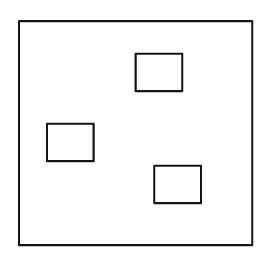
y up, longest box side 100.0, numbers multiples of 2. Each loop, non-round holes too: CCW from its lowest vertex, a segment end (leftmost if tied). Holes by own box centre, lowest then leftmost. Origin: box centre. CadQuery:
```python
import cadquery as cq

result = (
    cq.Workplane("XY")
    .moveTo(-50.0, -48.0)
    .lineTo(50.0, -48.0)
    .lineTo(50.0, 48.0)
    .lineTo(-50.0, 48.0)
    .close()
    .moveTo(8.0, -30.0)
    .lineTo(28.0, -30.0)
    .lineTo(28.0, -14.0)
    .lineTo(8.0, -14.0)
    .close()
    .moveTo(-38.0, -12.0)
    .lineTo(-18.0, -12.0)
    .lineTo(-18.0, 4.0)
    .lineTo(-38.0, 4.0)
    .close()
    .moveTo(0.0, 18.0)
    .lineTo(20.0, 18.0)
    .lineTo(20.0, 34.0)
    .lineTo(0.0, 34.0)
    .close()
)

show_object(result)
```